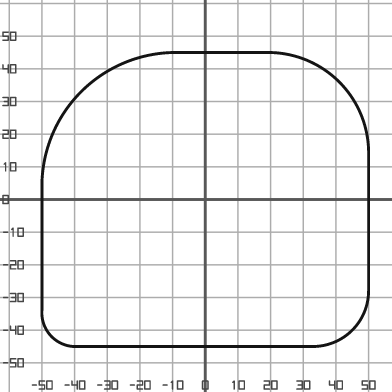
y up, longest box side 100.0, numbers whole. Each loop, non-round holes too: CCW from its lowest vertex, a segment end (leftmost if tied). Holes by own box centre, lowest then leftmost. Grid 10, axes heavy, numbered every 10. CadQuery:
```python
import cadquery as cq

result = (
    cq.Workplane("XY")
    .moveTo(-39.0, -45.0)
    .lineTo(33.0, -45.0)
    .threePointArc((45.0, -40.0), (50.0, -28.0))
    .lineTo(50.0, 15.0)
    .threePointArc((41.0, 36.0), (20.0, 45.0))
    .lineTo(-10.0, 45.0)
    .threePointArc((-38.0, 33.0), (-50.0, 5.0))
    .lineTo(-50.0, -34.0)
    .threePointArc((-47.0, -42.0), (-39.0, -45.0))
    .close()
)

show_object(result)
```